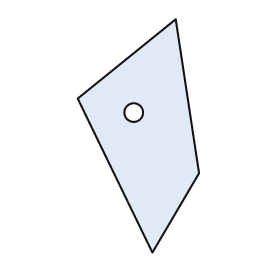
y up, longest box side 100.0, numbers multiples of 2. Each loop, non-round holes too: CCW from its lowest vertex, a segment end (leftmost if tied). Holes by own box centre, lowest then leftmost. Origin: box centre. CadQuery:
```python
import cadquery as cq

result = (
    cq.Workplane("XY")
    .moveTo(6.0, -50.0)
    .lineTo(26.0, -16.0)
    .lineTo(16.0, 50.0)
    .lineTo(-26.0, 16.0)
    .close()
    .moveTo(-2.0, 10.0)
    .circle(4.0)
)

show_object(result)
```